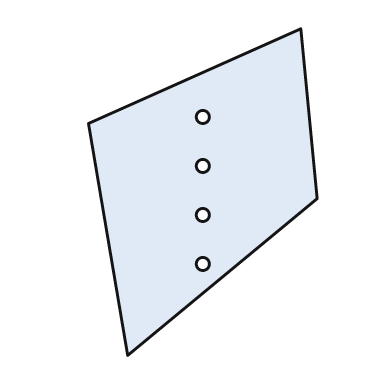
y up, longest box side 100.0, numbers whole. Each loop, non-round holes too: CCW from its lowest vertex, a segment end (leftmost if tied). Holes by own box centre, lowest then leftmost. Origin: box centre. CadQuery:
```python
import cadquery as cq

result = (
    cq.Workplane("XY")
    .moveTo(-23.0, -50.0)
    .lineTo(35.0, -2.0)
    .lineTo(30.0, 50.0)
    .lineTo(-35.0, 21.0)
    .close()
    .moveTo(0.0, -22.0)
    .circle(2.0)
    .moveTo(0.0, -7.0)
    .circle(2.0)
    .moveTo(0.0, 8.0)
    .circle(2.0)
    .moveTo(0.0, 23.0)
    .circle(2.0)
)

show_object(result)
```